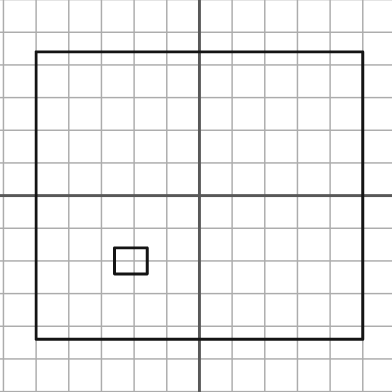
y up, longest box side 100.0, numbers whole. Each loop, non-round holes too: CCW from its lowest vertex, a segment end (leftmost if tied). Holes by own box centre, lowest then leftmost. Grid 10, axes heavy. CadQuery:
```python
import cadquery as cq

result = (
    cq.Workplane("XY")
    .moveTo(-50.0, -44.0)
    .lineTo(50.0, -44.0)
    .lineTo(50.0, 44.0)
    .lineTo(-50.0, 44.0)
    .close()
    .moveTo(-26.0, -24.0)
    .lineTo(-16.0, -24.0)
    .lineTo(-16.0, -16.0)
    .lineTo(-26.0, -16.0)
    .close()
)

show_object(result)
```